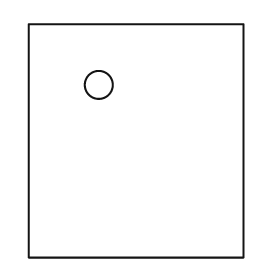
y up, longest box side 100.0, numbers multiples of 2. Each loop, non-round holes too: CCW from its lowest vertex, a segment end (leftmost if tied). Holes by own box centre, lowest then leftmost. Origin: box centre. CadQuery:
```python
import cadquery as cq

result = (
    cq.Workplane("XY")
    .moveTo(-46.0, -50.0)
    .lineTo(46.0, -50.0)
    .lineTo(46.0, 50.0)
    .lineTo(-46.0, 50.0)
    .close()
    .moveTo(-16.0, 24.0)
    .circle(6.0)
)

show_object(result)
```